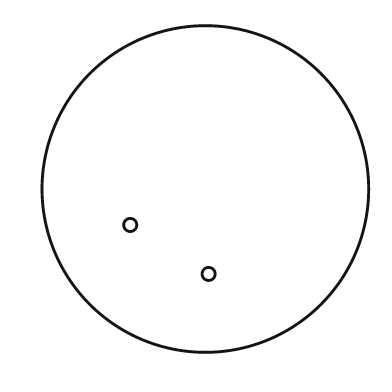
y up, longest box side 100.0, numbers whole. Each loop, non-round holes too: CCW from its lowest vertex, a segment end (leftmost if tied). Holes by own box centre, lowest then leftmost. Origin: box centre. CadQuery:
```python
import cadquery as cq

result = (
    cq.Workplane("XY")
    .moveTo(0.0, 0.0)
    .circle(50.0)
    .moveTo(1.0, -26.0)
    .circle(2.0)
    .moveTo(-23.0, -11.0)
    .circle(2.0)
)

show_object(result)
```